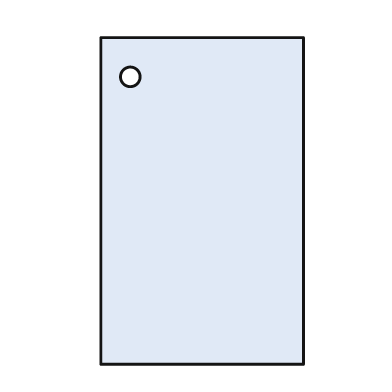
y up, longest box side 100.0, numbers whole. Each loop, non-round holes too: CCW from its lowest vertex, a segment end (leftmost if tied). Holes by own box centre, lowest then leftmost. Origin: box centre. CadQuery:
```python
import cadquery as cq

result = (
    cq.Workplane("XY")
    .moveTo(-31.0, -50.0)
    .lineTo(31.0, -50.0)
    .lineTo(31.0, 50.0)
    .lineTo(-31.0, 50.0)
    .close()
    .moveTo(-22.0, 38.0)
    .circle(3.0)
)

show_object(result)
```